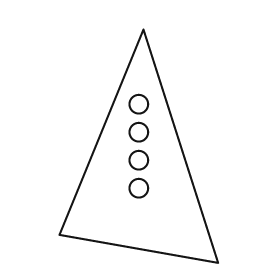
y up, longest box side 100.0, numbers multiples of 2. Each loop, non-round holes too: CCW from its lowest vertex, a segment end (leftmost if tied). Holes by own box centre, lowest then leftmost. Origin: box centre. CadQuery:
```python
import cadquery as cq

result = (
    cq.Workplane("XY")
    .moveTo(34.0, -50.0)
    .lineTo(2.0, 50.0)
    .lineTo(-34.0, -38.0)
    .close()
    .moveTo(0.0, -18.0)
    .circle(4.0)
    .moveTo(0.0, -6.0)
    .circle(4.0)
    .moveTo(0.0, 6.0)
    .circle(4.0)
    .moveTo(0.0, 18.0)
    .circle(4.0)
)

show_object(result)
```